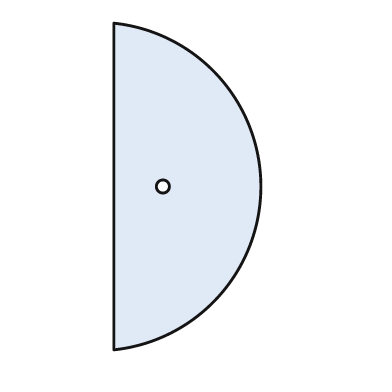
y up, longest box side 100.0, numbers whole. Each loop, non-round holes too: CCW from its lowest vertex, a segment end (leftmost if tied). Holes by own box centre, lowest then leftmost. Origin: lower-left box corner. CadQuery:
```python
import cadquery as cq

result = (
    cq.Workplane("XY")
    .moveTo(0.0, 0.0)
    .threePointArc((45.0, 50.0), (0.0, 100.0))
    .close()
    .moveTo(15.0, 50.0)
    .circle(2.0)
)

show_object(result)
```